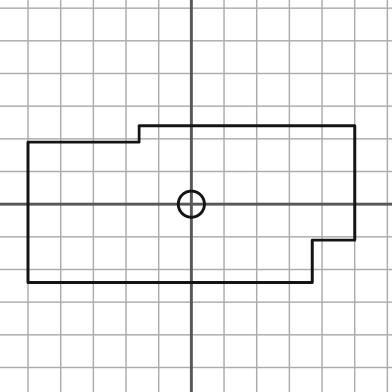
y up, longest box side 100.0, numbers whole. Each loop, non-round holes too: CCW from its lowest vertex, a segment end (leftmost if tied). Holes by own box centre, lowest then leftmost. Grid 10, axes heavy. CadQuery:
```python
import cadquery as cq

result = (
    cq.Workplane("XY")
    .moveTo(-50.0, -24.0)
    .lineTo(37.0, -24.0)
    .lineTo(37.0, -11.0)
    .lineTo(50.0, -11.0)
    .lineTo(50.0, 24.0)
    .lineTo(-16.0, 24.0)
    .lineTo(-16.0, 19.0)
    .lineTo(-50.0, 19.0)
    .close()
    .moveTo(0.0, 0.0)
    .circle(4.0)
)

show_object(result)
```